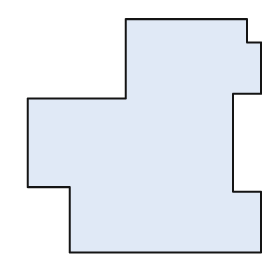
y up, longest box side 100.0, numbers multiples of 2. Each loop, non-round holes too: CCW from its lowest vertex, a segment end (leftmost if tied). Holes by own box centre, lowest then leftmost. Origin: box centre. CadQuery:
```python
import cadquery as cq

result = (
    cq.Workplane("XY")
    .moveTo(-32.0, -50.0)
    .lineTo(50.0, -50.0)
    .lineTo(50.0, -24.0)
    .lineTo(38.0, -24.0)
    .lineTo(38.0, 18.0)
    .lineTo(50.0, 18.0)
    .lineTo(50.0, 40.0)
    .lineTo(44.0, 40.0)
    .lineTo(44.0, 50.0)
    .lineTo(-8.0, 50.0)
    .lineTo(-8.0, 16.0)
    .lineTo(-50.0, 16.0)
    .lineTo(-50.0, -22.0)
    .lineTo(-32.0, -22.0)
    .close()
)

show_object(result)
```